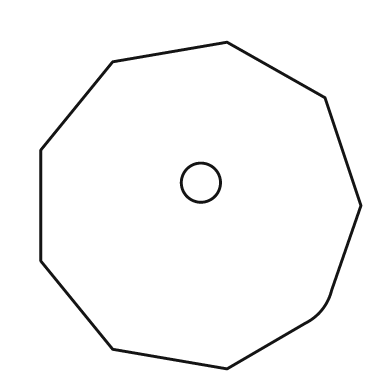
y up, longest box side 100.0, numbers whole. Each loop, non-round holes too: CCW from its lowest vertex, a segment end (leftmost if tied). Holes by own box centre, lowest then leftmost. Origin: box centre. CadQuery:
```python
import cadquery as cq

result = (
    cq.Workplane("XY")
    .moveTo(8.0, -50.0)
    .lineTo(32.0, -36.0)
    .threePointArc((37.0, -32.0), (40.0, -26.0))
    .lineTo(49.0, 0.0)
    .lineTo(38.0, 33.0)
    .lineTo(8.0, 50.0)
    .lineTo(-27.0, 44.0)
    .lineTo(-49.0, 17.0)
    .lineTo(-49.0, -17.0)
    .lineTo(-27.0, -44.0)
    .close()
    .moveTo(0.0, 7.0)
    .circle(6.0)
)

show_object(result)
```